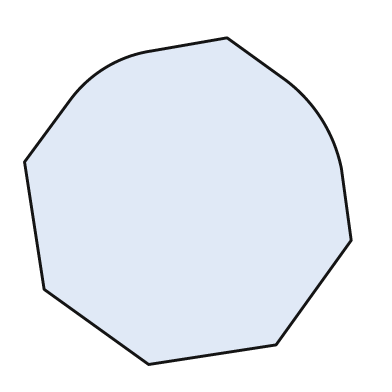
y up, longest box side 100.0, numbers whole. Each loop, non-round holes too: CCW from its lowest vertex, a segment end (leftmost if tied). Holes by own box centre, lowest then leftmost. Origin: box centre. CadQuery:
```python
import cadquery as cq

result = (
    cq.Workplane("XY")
    .moveTo(-12.0, -50.0)
    .lineTo(27.0, -44.0)
    .lineTo(50.0, -12.0)
    .lineTo(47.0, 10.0)
    .threePointArc((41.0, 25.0), (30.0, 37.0))
    .lineTo(12.0, 50.0)
    .lineTo(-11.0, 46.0)
    .threePointArc((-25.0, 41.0), (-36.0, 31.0))
    .lineTo(-50.0, 12.0)
    .lineTo(-44.0, -27.0)
    .close()
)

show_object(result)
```